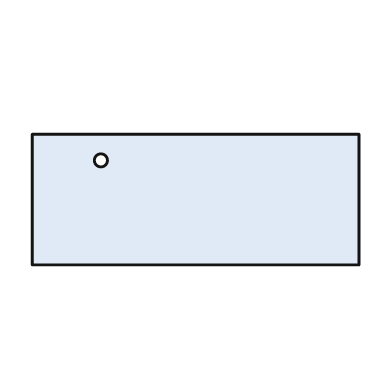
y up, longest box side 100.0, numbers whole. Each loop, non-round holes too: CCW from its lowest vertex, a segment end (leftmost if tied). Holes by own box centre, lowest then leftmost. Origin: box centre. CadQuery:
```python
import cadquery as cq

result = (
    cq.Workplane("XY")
    .moveTo(-50.0, -20.0)
    .lineTo(50.0, -20.0)
    .lineTo(50.0, 20.0)
    .lineTo(-50.0, 20.0)
    .close()
    .moveTo(-29.0, 12.0)
    .circle(2.0)
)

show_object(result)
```